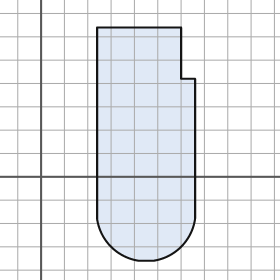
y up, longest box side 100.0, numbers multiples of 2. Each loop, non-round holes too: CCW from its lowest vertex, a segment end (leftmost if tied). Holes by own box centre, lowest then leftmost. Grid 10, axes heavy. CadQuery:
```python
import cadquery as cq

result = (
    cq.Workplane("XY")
    .moveTo(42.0, -36.0)
    .lineTo(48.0, -36.0)
    .threePointArc((60.0, -30.0), (66.0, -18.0))
    .lineTo(66.0, 42.0)
    .lineTo(60.0, 42.0)
    .lineTo(60.0, 64.0)
    .lineTo(24.0, 64.0)
    .lineTo(24.0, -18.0)
    .threePointArc((30.0, -30.0), (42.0, -36.0))
    .close()
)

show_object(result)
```